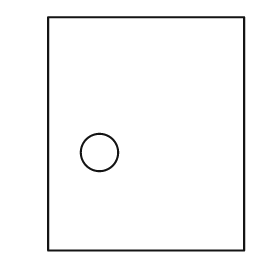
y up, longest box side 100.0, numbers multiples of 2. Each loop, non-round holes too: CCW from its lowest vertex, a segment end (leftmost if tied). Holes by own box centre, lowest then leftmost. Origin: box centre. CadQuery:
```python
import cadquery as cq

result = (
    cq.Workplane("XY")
    .moveTo(-42.0, -50.0)
    .lineTo(42.0, -50.0)
    .lineTo(42.0, 50.0)
    .lineTo(-42.0, 50.0)
    .close()
    .moveTo(-20.0, -8.0)
    .circle(8.0)
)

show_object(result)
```